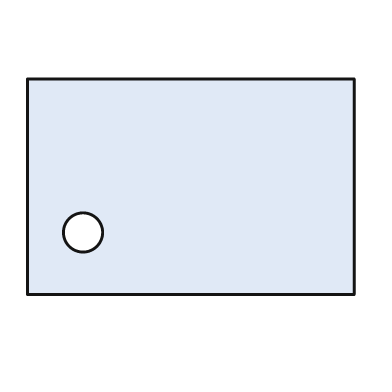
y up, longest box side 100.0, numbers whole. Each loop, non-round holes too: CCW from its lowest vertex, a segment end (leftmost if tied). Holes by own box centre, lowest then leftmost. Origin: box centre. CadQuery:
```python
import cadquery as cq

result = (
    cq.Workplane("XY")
    .moveTo(-50.0, -33.0)
    .lineTo(50.0, -33.0)
    .lineTo(50.0, 33.0)
    .lineTo(-50.0, 33.0)
    .close()
    .moveTo(-33.0, -14.0)
    .circle(6.0)
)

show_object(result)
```